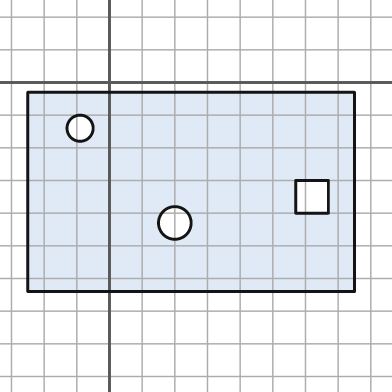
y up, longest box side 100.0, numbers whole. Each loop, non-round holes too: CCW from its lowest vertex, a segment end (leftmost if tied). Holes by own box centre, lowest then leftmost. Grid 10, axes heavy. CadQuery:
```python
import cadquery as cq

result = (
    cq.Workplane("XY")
    .moveTo(-25.0, -64.0)
    .lineTo(75.0, -64.0)
    .lineTo(75.0, -3.0)
    .lineTo(-25.0, -3.0)
    .close()
    .moveTo(20.0, -43.0)
    .circle(5.0)
    .moveTo(57.0, -40.0)
    .lineTo(67.0, -40.0)
    .lineTo(67.0, -30.0)
    .lineTo(57.0, -30.0)
    .close()
    .moveTo(-9.0, -14.0)
    .circle(4.0)
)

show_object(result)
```